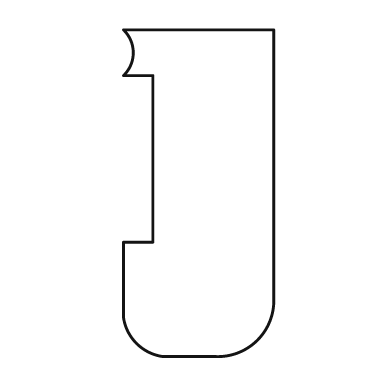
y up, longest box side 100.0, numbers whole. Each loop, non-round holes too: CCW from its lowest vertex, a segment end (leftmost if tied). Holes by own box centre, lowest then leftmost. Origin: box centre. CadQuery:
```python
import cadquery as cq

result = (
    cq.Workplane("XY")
    .moveTo(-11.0, -50.0)
    .lineTo(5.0, -50.0)
    .threePointArc((18.0, -45.0), (23.0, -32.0))
    .lineTo(23.0, 50.0)
    .lineTo(-23.0, 50.0)
    .threePointArc((-20.0, 43.0), (-23.0, 36.0))
    .lineTo(-14.0, 36.0)
    .lineTo(-14.0, -15.0)
    .lineTo(-23.0, -15.0)
    .lineTo(-23.0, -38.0)
    .threePointArc((-19.0, -46.0), (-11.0, -50.0))
    .close()
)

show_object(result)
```